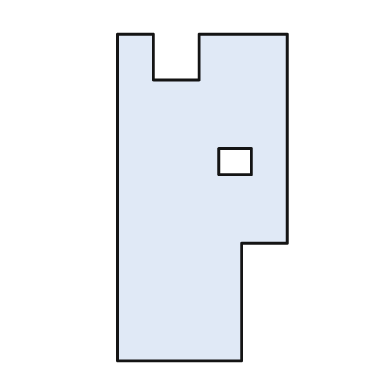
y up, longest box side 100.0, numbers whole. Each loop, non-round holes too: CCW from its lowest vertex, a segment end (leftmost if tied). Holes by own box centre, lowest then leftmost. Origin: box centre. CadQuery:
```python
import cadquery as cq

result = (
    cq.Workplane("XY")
    .moveTo(-26.0, -50.0)
    .lineTo(12.0, -50.0)
    .lineTo(12.0, -14.0)
    .lineTo(26.0, -14.0)
    .lineTo(26.0, 50.0)
    .lineTo(-1.0, 50.0)
    .lineTo(-1.0, 36.0)
    .lineTo(-15.0, 36.0)
    .lineTo(-15.0, 50.0)
    .lineTo(-26.0, 50.0)
    .close()
    .moveTo(5.0, 7.0)
    .lineTo(15.0, 7.0)
    .lineTo(15.0, 15.0)
    .lineTo(5.0, 15.0)
    .close()
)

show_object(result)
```